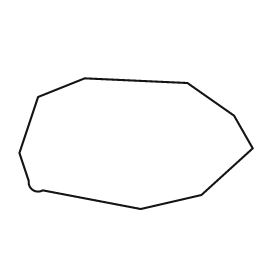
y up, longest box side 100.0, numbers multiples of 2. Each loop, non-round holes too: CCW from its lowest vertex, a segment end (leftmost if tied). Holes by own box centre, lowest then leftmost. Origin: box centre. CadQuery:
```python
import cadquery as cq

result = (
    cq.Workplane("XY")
    .moveTo(2.0, -28.0)
    .lineTo(28.0, -22.0)
    .lineTo(50.0, -2.0)
    .lineTo(42.0, 12.0)
    .lineTo(22.0, 26.0)
    .lineTo(-22.0, 28.0)
    .lineTo(-42.0, 20.0)
    .lineTo(-50.0, -4.0)
    .lineTo(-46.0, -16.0)
    .threePointArc((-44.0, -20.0), (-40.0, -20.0))
    .close()
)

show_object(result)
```